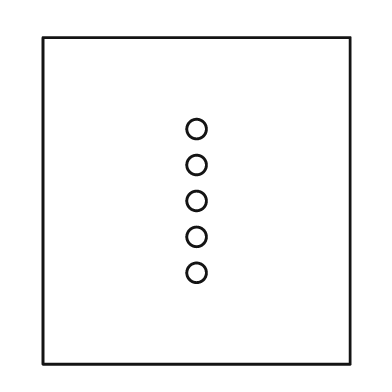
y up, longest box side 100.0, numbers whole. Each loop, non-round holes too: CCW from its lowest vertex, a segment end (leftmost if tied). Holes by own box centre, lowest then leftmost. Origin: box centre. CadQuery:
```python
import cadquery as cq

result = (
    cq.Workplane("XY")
    .moveTo(-47.0, -50.0)
    .lineTo(47.0, -50.0)
    .lineTo(47.0, 50.0)
    .lineTo(-47.0, 50.0)
    .close()
    .moveTo(0.0, -22.0)
    .circle(3.0)
    .moveTo(0.0, -11.0)
    .circle(3.0)
    .moveTo(0.0, 0.0)
    .circle(3.0)
    .moveTo(0.0, 11.0)
    .circle(3.0)
    .moveTo(0.0, 22.0)
    .circle(3.0)
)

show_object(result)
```